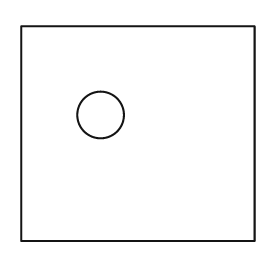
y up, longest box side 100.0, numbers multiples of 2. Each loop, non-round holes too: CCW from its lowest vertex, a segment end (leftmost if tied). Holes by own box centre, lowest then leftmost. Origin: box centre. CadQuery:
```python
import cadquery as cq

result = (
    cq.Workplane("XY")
    .moveTo(-50.0, -46.0)
    .lineTo(50.0, -46.0)
    .lineTo(50.0, 46.0)
    .lineTo(-50.0, 46.0)
    .close()
    .moveTo(-16.0, 8.0)
    .circle(10.0)
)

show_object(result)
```